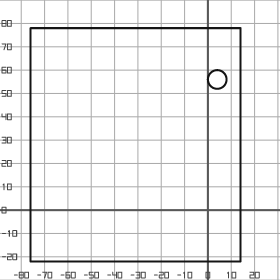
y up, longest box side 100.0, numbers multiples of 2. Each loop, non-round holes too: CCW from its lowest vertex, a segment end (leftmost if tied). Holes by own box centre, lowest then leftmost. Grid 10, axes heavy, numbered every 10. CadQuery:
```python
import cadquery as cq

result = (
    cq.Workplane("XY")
    .moveTo(-76.0, -22.0)
    .lineTo(14.0, -22.0)
    .lineTo(14.0, 78.0)
    .lineTo(-76.0, 78.0)
    .close()
    .moveTo(4.0, 56.0)
    .circle(4.0)
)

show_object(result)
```